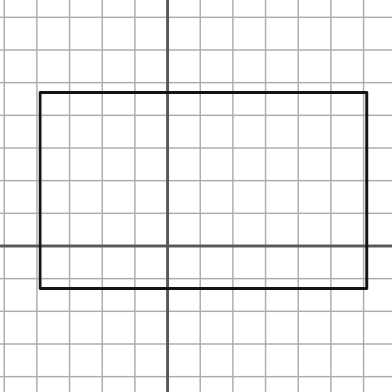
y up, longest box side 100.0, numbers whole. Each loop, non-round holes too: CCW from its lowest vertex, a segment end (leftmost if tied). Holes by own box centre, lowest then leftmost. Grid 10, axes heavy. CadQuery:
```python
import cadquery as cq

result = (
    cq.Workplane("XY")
    .moveTo(-39.0, -13.0)
    .lineTo(61.0, -13.0)
    .lineTo(61.0, 47.0)
    .lineTo(-39.0, 47.0)
    .close()
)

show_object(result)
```